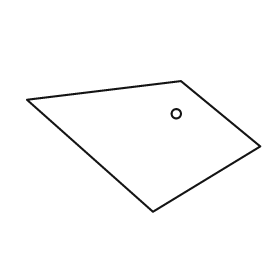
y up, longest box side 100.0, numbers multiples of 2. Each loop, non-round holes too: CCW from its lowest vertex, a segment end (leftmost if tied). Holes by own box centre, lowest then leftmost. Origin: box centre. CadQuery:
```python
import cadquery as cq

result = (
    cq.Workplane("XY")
    .moveTo(4.0, -28.0)
    .lineTo(50.0, 0.0)
    .lineTo(16.0, 28.0)
    .lineTo(-50.0, 20.0)
    .close()
    .moveTo(14.0, 14.0)
    .circle(2.0)
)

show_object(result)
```